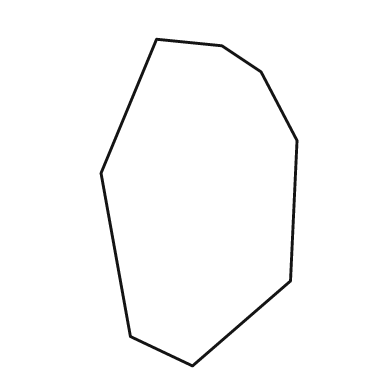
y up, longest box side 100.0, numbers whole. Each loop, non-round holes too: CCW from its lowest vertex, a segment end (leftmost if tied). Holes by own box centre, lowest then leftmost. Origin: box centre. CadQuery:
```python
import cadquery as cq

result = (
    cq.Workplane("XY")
    .moveTo(-2.0, -50.0)
    .lineTo(28.0, -24.0)
    .lineTo(30.0, 19.0)
    .lineTo(19.0, 40.0)
    .lineTo(7.0, 48.0)
    .lineTo(-13.0, 50.0)
    .lineTo(-30.0, 9.0)
    .lineTo(-21.0, -41.0)
    .close()
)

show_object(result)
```